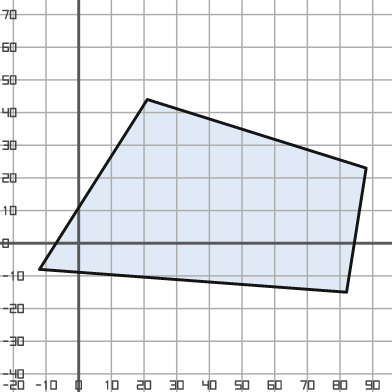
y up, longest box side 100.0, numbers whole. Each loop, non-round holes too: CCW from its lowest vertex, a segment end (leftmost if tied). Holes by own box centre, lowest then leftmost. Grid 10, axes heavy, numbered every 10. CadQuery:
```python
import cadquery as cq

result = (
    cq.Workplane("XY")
    .moveTo(82.0, -15.0)
    .lineTo(88.0, 23.0)
    .lineTo(21.0, 44.0)
    .lineTo(-12.0, -8.0)
    .close()
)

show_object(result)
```